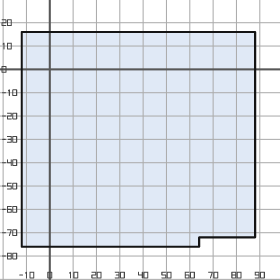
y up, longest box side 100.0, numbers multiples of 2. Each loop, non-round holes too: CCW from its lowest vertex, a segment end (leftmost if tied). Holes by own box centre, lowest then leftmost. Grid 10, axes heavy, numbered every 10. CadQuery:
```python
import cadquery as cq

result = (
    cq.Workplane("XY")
    .moveTo(-12.0, -76.0)
    .lineTo(64.0, -76.0)
    .lineTo(64.0, -72.0)
    .lineTo(88.0, -72.0)
    .lineTo(88.0, 16.0)
    .lineTo(-12.0, 16.0)
    .close()
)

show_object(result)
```